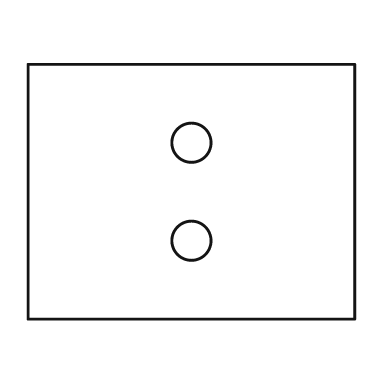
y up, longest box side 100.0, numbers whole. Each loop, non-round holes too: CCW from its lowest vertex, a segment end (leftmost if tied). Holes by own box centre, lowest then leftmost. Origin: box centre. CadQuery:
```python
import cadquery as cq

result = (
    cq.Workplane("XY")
    .moveTo(-50.0, -39.0)
    .lineTo(50.0, -39.0)
    .lineTo(50.0, 39.0)
    .lineTo(-50.0, 39.0)
    .close()
    .moveTo(0.0, -15.0)
    .circle(6.0)
    .moveTo(0.0, 15.0)
    .circle(6.0)
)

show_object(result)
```